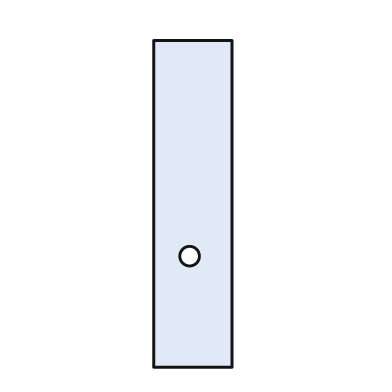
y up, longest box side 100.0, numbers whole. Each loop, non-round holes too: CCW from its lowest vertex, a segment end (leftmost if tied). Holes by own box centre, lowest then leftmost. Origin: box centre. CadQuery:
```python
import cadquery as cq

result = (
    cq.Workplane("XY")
    .moveTo(-12.0, -50.0)
    .lineTo(12.0, -50.0)
    .lineTo(12.0, 50.0)
    .lineTo(-12.0, 50.0)
    .close()
    .moveTo(-1.0, -16.0)
    .circle(3.0)
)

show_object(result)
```